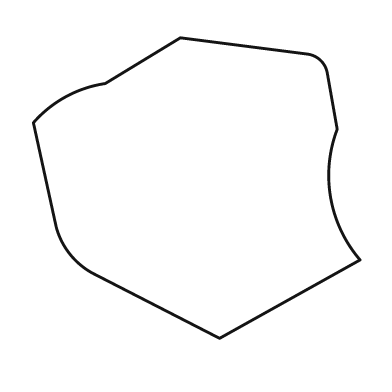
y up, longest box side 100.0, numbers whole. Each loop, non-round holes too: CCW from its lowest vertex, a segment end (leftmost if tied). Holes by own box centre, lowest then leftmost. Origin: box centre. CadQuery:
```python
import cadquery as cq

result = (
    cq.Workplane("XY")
    .moveTo(7.0, -46.0)
    .lineTo(50.0, -22.0)
    .threePointArc((41.0, -3.0), (43.0, 18.0))
    .lineTo(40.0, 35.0)
    .threePointArc((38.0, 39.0), (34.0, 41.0))
    .lineTo(-5.0, 46.0)
    .lineTo(-28.0, 32.0)
    .threePointArc((-40.0, 28.0), (-50.0, 20.0))
    .lineTo(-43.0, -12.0)
    .threePointArc((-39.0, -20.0), (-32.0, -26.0))
    .close()
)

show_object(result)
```